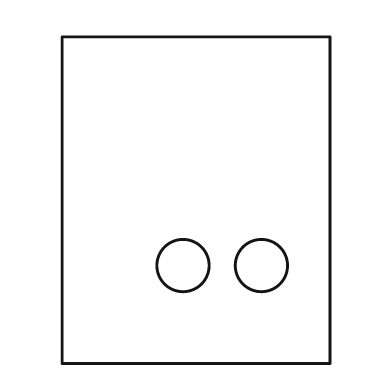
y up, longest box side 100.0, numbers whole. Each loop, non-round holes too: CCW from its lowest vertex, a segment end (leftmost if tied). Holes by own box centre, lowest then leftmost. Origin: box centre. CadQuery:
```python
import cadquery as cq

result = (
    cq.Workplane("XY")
    .moveTo(-41.0, -50.0)
    .lineTo(41.0, -50.0)
    .lineTo(41.0, 50.0)
    .lineTo(-41.0, 50.0)
    .close()
    .moveTo(-4.0, -20.0)
    .circle(8.0)
    .moveTo(20.0, -20.0)
    .circle(8.0)
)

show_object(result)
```